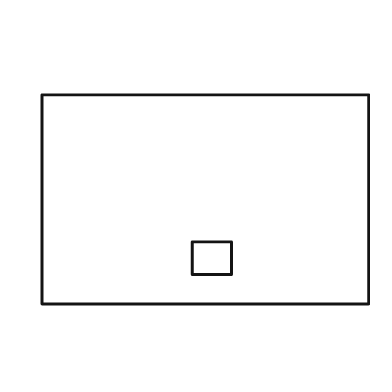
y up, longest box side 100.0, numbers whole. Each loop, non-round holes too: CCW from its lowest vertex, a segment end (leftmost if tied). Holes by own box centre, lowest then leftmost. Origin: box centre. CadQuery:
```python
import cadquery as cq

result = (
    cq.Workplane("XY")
    .moveTo(-50.0, -32.0)
    .lineTo(50.0, -32.0)
    .lineTo(50.0, 32.0)
    .lineTo(-50.0, 32.0)
    .close()
    .moveTo(-4.0, -23.0)
    .lineTo(8.0, -23.0)
    .lineTo(8.0, -13.0)
    .lineTo(-4.0, -13.0)
    .close()
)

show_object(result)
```